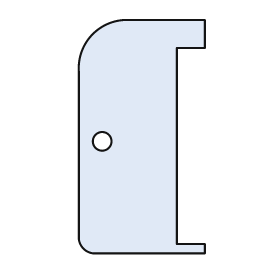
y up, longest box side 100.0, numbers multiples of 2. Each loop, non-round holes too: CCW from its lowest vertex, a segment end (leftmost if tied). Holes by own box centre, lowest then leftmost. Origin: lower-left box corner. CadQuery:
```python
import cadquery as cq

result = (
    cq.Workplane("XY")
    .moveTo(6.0, 0.0)
    .lineTo(54.0, 0.0)
    .lineTo(54.0, 4.0)
    .lineTo(42.0, 4.0)
    .lineTo(42.0, 88.0)
    .lineTo(54.0, 88.0)
    .lineTo(54.0, 100.0)
    .lineTo(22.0, 100.0)
    .threePointArc((6.0, 94.0), (0.0, 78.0))
    .lineTo(0.0, 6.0)
    .threePointArc((2.0, 2.0), (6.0, 0.0))
    .close()
    .moveTo(10.0, 48.0)
    .circle(4.0)
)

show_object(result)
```